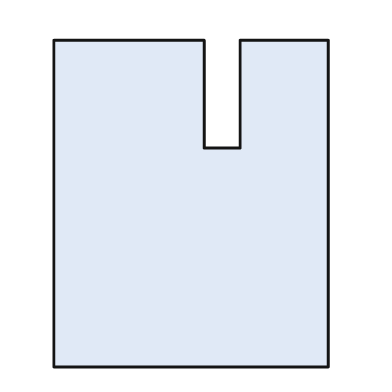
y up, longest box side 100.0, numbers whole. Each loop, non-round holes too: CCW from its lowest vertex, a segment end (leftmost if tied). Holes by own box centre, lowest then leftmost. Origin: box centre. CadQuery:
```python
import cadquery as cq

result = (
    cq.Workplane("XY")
    .moveTo(-42.0, -50.0)
    .lineTo(42.0, -50.0)
    .lineTo(42.0, 50.0)
    .lineTo(15.0, 50.0)
    .lineTo(15.0, 17.0)
    .lineTo(4.0, 17.0)
    .lineTo(4.0, 50.0)
    .lineTo(-42.0, 50.0)
    .close()
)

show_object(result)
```